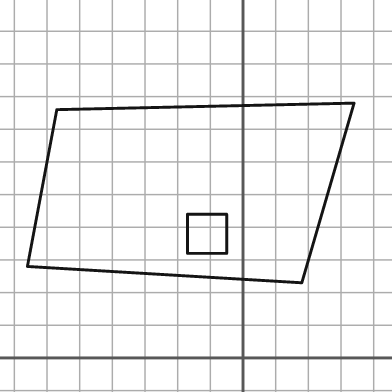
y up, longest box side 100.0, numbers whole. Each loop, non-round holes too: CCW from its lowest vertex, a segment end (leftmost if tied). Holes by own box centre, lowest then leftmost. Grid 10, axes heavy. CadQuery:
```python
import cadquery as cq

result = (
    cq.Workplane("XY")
    .moveTo(18.0, 23.0)
    .lineTo(34.0, 78.0)
    .lineTo(-57.0, 76.0)
    .lineTo(-66.0, 28.0)
    .close()
    .moveTo(-17.0, 32.0)
    .lineTo(-5.0, 32.0)
    .lineTo(-5.0, 44.0)
    .lineTo(-17.0, 44.0)
    .close()
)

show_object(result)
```